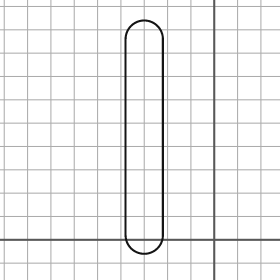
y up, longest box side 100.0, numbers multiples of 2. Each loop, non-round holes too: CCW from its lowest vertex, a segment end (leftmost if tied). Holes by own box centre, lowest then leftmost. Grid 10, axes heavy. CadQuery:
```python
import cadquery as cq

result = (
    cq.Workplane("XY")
    .moveTo(-38.0, 2.0)
    .threePointArc((-30.0, -6.0), (-22.0, 2.0))
    .lineTo(-22.0, 86.0)
    .threePointArc((-30.0, 94.0), (-38.0, 86.0))
    .close()
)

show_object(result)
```